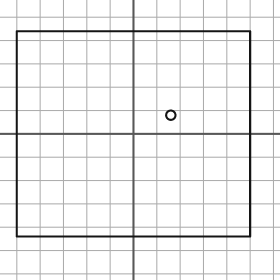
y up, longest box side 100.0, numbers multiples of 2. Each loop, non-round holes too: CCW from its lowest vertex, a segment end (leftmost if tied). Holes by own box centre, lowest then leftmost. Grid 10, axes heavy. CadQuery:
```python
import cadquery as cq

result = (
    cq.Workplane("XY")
    .moveTo(-50.0, -44.0)
    .lineTo(50.0, -44.0)
    .lineTo(50.0, 44.0)
    .lineTo(-50.0, 44.0)
    .close()
    .moveTo(16.0, 8.0)
    .circle(2.0)
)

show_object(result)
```